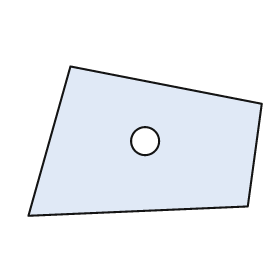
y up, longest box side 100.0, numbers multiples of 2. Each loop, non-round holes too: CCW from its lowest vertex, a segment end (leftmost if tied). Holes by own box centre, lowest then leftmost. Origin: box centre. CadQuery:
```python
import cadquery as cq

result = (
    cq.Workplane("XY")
    .moveTo(-50.0, -32.0)
    .lineTo(44.0, -28.0)
    .lineTo(50.0, 16.0)
    .lineTo(-32.0, 32.0)
    .close()
    .moveTo(0.0, 0.0)
    .circle(6.0)
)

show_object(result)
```